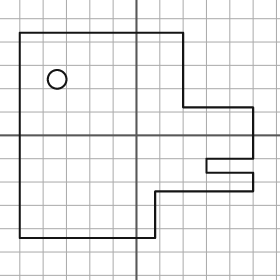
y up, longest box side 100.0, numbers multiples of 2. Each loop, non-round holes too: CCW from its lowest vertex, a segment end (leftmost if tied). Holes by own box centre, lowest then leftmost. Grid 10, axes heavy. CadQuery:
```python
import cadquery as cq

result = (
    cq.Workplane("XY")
    .moveTo(-50.0, -44.0)
    .lineTo(8.0, -44.0)
    .lineTo(8.0, -24.0)
    .lineTo(50.0, -24.0)
    .lineTo(50.0, -16.0)
    .lineTo(30.0, -16.0)
    .lineTo(30.0, -10.0)
    .lineTo(50.0, -10.0)
    .lineTo(50.0, 12.0)
    .lineTo(20.0, 12.0)
    .lineTo(20.0, 44.0)
    .lineTo(-50.0, 44.0)
    .close()
    .moveTo(-34.0, 24.0)
    .circle(4.0)
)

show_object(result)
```